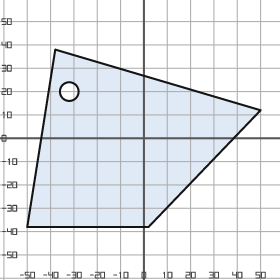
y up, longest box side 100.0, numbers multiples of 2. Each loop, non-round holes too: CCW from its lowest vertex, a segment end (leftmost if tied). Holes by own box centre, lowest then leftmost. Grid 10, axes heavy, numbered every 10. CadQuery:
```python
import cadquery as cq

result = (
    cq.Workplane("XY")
    .moveTo(-50.0, -38.0)
    .lineTo(2.0, -38.0)
    .lineTo(50.0, 12.0)
    .lineTo(-38.0, 38.0)
    .close()
    .moveTo(-32.0, 20.0)
    .circle(4.0)
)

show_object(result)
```